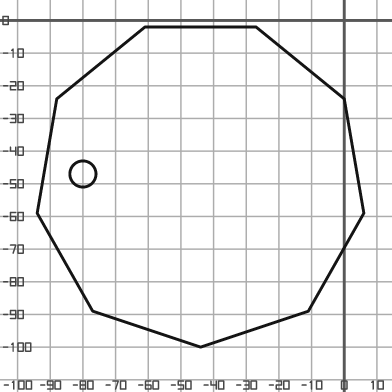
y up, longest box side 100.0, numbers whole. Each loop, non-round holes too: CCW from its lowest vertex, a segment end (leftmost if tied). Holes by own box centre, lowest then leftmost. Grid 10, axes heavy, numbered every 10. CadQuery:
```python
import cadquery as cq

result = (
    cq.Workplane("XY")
    .moveTo(-44.0, -100.0)
    .lineTo(-11.0, -89.0)
    .lineTo(6.0, -59.0)
    .lineTo(0.0, -24.0)
    .lineTo(-27.0, -2.0)
    .lineTo(-61.0, -2.0)
    .lineTo(-88.0, -24.0)
    .lineTo(-94.0, -59.0)
    .lineTo(-77.0, -89.0)
    .close()
    .moveTo(-80.0, -47.0)
    .circle(4.0)
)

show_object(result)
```